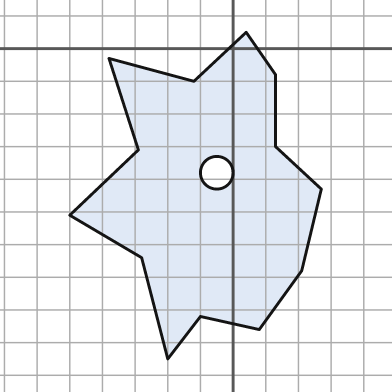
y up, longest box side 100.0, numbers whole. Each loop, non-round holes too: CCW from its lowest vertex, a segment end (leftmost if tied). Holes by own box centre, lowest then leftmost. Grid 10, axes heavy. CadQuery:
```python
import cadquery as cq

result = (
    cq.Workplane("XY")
    .moveTo(-20.0, -95.0)
    .lineTo(-10.0, -82.0)
    .lineTo(8.0, -86.0)
    .lineTo(21.0, -68.0)
    .lineTo(27.0, -43.0)
    .lineTo(13.0, -30.0)
    .lineTo(13.0, -8.0)
    .lineTo(4.0, 5.0)
    .lineTo(-12.0, -10.0)
    .lineTo(-38.0, -3.0)
    .lineTo(-29.0, -31.0)
    .lineTo(-50.0, -51.0)
    .lineTo(-28.0, -64.0)
    .close()
    .moveTo(-5.0, -38.0)
    .circle(5.0)
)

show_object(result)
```